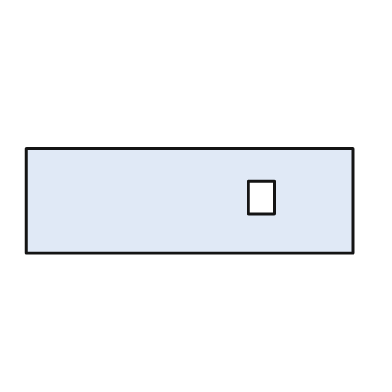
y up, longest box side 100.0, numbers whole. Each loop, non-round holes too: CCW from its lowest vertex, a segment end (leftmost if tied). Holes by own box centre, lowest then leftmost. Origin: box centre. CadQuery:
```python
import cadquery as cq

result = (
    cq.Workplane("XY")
    .moveTo(-50.0, -16.0)
    .lineTo(50.0, -16.0)
    .lineTo(50.0, 16.0)
    .lineTo(-50.0, 16.0)
    .close()
    .moveTo(18.0, -4.0)
    .lineTo(26.0, -4.0)
    .lineTo(26.0, 6.0)
    .lineTo(18.0, 6.0)
    .close()
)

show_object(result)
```